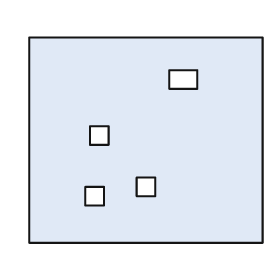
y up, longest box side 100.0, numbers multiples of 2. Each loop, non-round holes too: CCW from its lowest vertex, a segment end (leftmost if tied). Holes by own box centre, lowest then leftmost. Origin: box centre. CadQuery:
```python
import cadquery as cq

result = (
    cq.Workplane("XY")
    .moveTo(-50.0, -44.0)
    .lineTo(50.0, -44.0)
    .lineTo(50.0, 44.0)
    .lineTo(-50.0, 44.0)
    .close()
    .moveTo(-26.0, -28.0)
    .lineTo(-18.0, -28.0)
    .lineTo(-18.0, -20.0)
    .lineTo(-26.0, -20.0)
    .close()
    .moveTo(-4.0, -24.0)
    .lineTo(4.0, -24.0)
    .lineTo(4.0, -16.0)
    .lineTo(-4.0, -16.0)
    .close()
    .moveTo(-24.0, -2.0)
    .lineTo(-16.0, -2.0)
    .lineTo(-16.0, 6.0)
    .lineTo(-24.0, 6.0)
    .close()
    .moveTo(10.0, 22.0)
    .lineTo(22.0, 22.0)
    .lineTo(22.0, 30.0)
    .lineTo(10.0, 30.0)
    .close()
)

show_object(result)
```